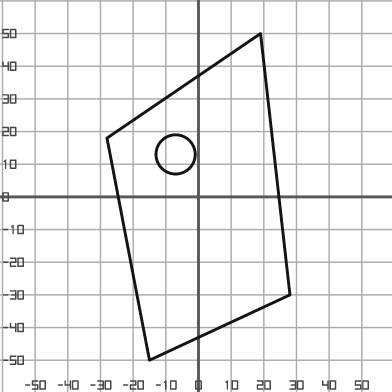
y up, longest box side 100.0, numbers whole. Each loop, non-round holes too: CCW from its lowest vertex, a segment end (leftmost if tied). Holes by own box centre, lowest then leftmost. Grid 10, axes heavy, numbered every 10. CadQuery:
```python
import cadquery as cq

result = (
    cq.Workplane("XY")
    .moveTo(-15.0, -50.0)
    .lineTo(28.0, -30.0)
    .lineTo(19.0, 50.0)
    .lineTo(-28.0, 18.0)
    .close()
    .moveTo(-7.0, 13.0)
    .circle(6.0)
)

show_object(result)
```